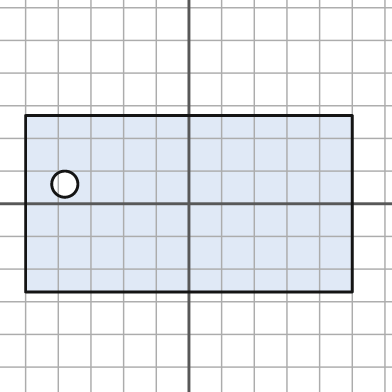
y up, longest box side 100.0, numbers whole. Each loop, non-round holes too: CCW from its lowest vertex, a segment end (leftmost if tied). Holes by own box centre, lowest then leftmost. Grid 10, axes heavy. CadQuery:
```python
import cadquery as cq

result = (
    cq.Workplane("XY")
    .moveTo(-50.0, -27.0)
    .lineTo(50.0, -27.0)
    .lineTo(50.0, 27.0)
    .lineTo(-50.0, 27.0)
    .close()
    .moveTo(-38.0, 6.0)
    .circle(4.0)
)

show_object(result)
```